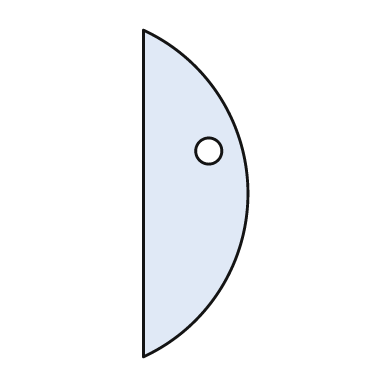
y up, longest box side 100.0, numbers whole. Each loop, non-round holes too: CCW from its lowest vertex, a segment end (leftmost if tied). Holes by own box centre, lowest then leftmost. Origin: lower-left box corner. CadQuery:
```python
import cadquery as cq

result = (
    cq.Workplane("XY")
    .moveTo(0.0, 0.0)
    .threePointArc((32.0, 50.0), (0.0, 100.0))
    .close()
    .moveTo(20.0, 63.0)
    .circle(4.0)
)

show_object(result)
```